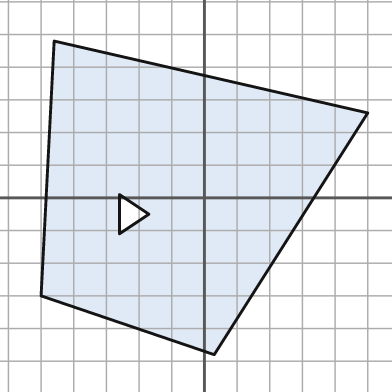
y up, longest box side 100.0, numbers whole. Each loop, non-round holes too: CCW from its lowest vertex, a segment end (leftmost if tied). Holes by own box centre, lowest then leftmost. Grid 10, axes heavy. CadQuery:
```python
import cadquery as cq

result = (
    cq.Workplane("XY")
    .moveTo(3.0, -48.0)
    .lineTo(50.0, 26.0)
    .lineTo(-46.0, 48.0)
    .lineTo(-50.0, -30.0)
    .close()
    .moveTo(-26.0, -11.0)
    .lineTo(-17.0, -5.0)
    .lineTo(-26.0, 1.0)
    .close()
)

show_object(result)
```